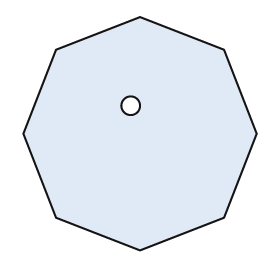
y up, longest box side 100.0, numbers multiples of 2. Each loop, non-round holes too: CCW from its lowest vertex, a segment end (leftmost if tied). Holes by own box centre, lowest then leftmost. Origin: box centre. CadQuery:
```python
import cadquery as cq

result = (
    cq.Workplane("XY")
    .moveTo(0.0, -50.0)
    .lineTo(36.0, -36.0)
    .lineTo(50.0, 0.0)
    .lineTo(36.0, 36.0)
    .lineTo(0.0, 50.0)
    .lineTo(-36.0, 36.0)
    .lineTo(-50.0, 0.0)
    .lineTo(-36.0, -36.0)
    .close()
    .moveTo(-4.0, 12.0)
    .circle(4.0)
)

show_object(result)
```